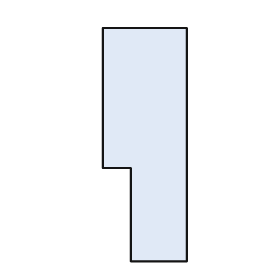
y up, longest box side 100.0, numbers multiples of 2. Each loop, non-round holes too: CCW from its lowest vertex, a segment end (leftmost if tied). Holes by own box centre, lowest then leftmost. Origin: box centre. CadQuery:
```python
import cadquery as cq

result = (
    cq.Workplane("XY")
    .moveTo(-6.0, -50.0)
    .lineTo(18.0, -50.0)
    .lineTo(18.0, 50.0)
    .lineTo(-18.0, 50.0)
    .lineTo(-18.0, -10.0)
    .lineTo(-6.0, -10.0)
    .close()
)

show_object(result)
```